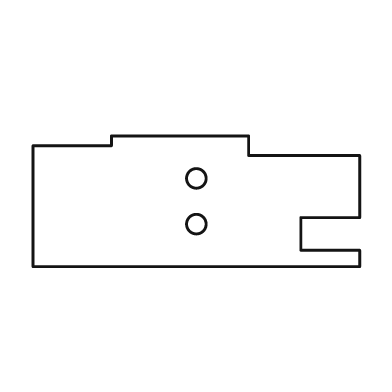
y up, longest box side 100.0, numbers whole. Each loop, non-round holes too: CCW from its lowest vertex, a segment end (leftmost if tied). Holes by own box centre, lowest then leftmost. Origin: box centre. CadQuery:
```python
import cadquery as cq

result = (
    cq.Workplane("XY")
    .moveTo(-50.0, -20.0)
    .lineTo(50.0, -20.0)
    .lineTo(50.0, -15.0)
    .lineTo(32.0, -15.0)
    .lineTo(32.0, -5.0)
    .lineTo(50.0, -5.0)
    .lineTo(50.0, 14.0)
    .lineTo(16.0, 14.0)
    .lineTo(16.0, 20.0)
    .lineTo(-26.0, 20.0)
    .lineTo(-26.0, 17.0)
    .lineTo(-50.0, 17.0)
    .close()
    .moveTo(0.0, -7.0)
    .circle(3.0)
    .moveTo(0.0, 7.0)
    .circle(3.0)
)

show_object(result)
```